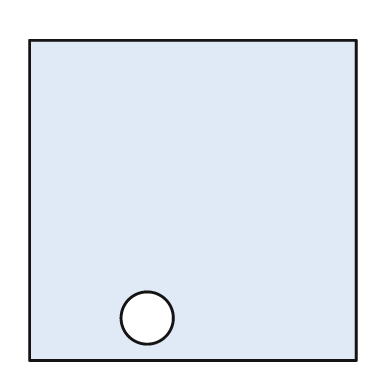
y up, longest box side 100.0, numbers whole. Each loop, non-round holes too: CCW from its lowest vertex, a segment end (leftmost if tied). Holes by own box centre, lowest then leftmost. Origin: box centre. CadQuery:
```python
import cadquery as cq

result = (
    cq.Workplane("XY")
    .moveTo(-50.0, -49.0)
    .lineTo(50.0, -49.0)
    .lineTo(50.0, 49.0)
    .lineTo(-50.0, 49.0)
    .close()
    .moveTo(-14.0, -36.0)
    .circle(8.0)
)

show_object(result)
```